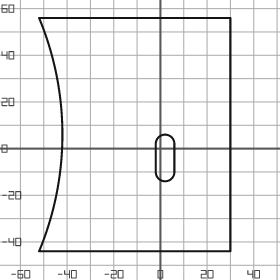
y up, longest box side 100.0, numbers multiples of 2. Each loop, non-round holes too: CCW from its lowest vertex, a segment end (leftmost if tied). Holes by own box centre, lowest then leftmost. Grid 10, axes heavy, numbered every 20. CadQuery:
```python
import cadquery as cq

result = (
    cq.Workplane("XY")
    .moveTo(-52.0, -44.0)
    .lineTo(30.0, -44.0)
    .lineTo(30.0, 56.0)
    .lineTo(-52.0, 56.0)
    .threePointArc((-42.0, 6.0), (-52.0, -44.0))
    .close()
    .moveTo(-2.0, -10.0)
    .threePointArc((2.0, -14.0), (6.0, -10.0))
    .lineTo(6.0, 2.0)
    .threePointArc((2.0, 6.0), (-2.0, 2.0))
    .close()
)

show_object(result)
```